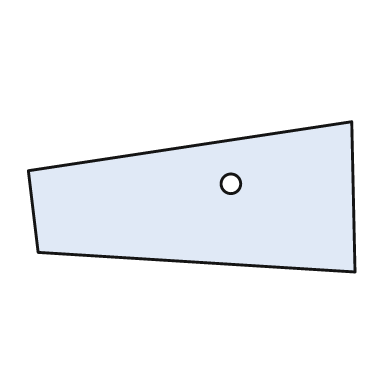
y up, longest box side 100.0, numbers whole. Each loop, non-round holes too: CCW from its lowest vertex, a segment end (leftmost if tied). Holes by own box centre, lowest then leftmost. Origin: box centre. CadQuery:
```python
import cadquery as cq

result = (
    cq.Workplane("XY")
    .moveTo(50.0, -23.0)
    .lineTo(49.0, 23.0)
    .lineTo(-50.0, 8.0)
    .lineTo(-47.0, -17.0)
    .close()
    .moveTo(12.0, 4.0)
    .circle(3.0)
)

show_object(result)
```